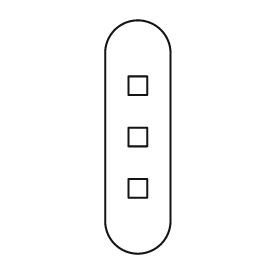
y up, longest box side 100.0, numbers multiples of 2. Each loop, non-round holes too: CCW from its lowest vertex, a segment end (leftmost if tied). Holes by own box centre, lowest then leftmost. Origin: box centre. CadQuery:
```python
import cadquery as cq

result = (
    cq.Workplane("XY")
    .moveTo(-14.0, -36.0)
    .threePointArc((0.0, -50.0), (14.0, -36.0))
    .lineTo(14.0, 36.0)
    .threePointArc((0.0, 50.0), (-14.0, 36.0))
    .close()
    .moveTo(-4.0, -26.0)
    .lineTo(4.0, -26.0)
    .lineTo(4.0, -18.0)
    .lineTo(-4.0, -18.0)
    .close()
    .moveTo(-4.0, -4.0)
    .lineTo(4.0, -4.0)
    .lineTo(4.0, 4.0)
    .lineTo(-4.0, 4.0)
    .close()
    .moveTo(-4.0, 18.0)
    .lineTo(4.0, 18.0)
    .lineTo(4.0, 26.0)
    .lineTo(-4.0, 26.0)
    .close()
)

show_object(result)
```